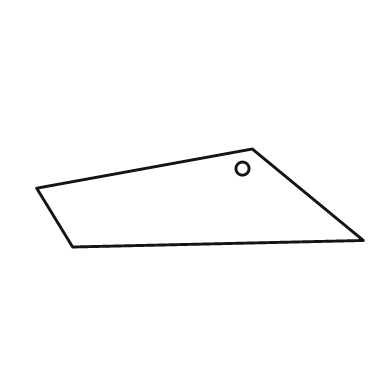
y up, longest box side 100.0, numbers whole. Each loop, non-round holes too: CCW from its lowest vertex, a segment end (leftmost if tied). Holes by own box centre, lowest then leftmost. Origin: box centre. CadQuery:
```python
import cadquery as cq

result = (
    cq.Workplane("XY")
    .moveTo(-39.0, -15.0)
    .lineTo(50.0, -13.0)
    .lineTo(16.0, 15.0)
    .lineTo(-50.0, 3.0)
    .close()
    .moveTo(13.0, 9.0)
    .circle(2.0)
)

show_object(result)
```